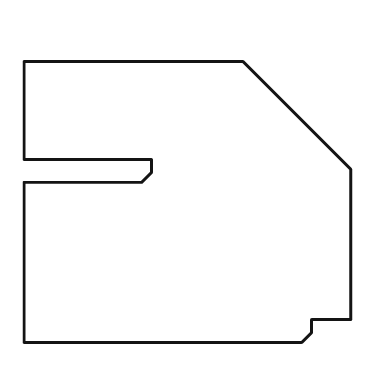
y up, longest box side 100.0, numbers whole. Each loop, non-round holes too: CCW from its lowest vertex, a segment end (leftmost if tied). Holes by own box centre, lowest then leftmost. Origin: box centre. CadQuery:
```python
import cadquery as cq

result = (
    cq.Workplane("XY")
    .moveTo(-50.0, -43.0)
    .lineTo(35.0, -43.0)
    .lineTo(38.0, -40.0)
    .lineTo(38.0, -36.0)
    .lineTo(50.0, -36.0)
    .lineTo(50.0, 10.0)
    .lineTo(17.0, 43.0)
    .lineTo(-50.0, 43.0)
    .lineTo(-50.0, 13.0)
    .lineTo(-11.0, 13.0)
    .lineTo(-11.0, 9.0)
    .lineTo(-14.0, 6.0)
    .lineTo(-50.0, 6.0)
    .close()
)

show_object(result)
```